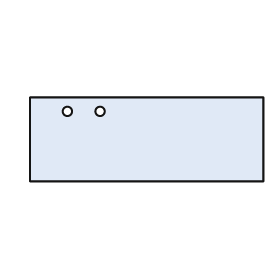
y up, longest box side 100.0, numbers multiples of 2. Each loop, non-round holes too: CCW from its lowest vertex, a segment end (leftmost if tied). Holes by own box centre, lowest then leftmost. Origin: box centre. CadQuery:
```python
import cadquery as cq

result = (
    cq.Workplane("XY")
    .moveTo(-50.0, -18.0)
    .lineTo(50.0, -18.0)
    .lineTo(50.0, 18.0)
    .lineTo(-50.0, 18.0)
    .close()
    .moveTo(-34.0, 12.0)
    .circle(2.0)
    .moveTo(-20.0, 12.0)
    .circle(2.0)
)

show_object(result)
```